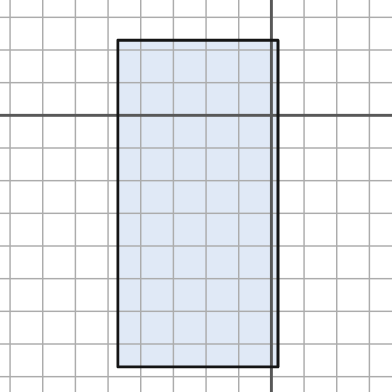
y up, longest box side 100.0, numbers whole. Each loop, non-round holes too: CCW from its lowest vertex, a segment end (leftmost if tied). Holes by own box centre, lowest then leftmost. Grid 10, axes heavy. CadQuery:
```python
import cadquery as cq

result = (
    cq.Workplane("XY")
    .moveTo(-47.0, -77.0)
    .lineTo(2.0, -77.0)
    .lineTo(2.0, 23.0)
    .lineTo(-47.0, 23.0)
    .close()
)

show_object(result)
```